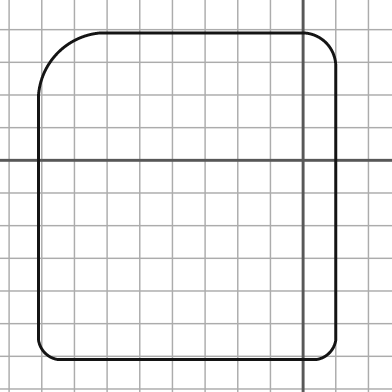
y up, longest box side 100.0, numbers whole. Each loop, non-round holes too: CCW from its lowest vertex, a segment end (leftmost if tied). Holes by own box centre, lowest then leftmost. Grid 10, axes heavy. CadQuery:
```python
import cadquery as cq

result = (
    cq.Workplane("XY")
    .moveTo(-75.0, -61.0)
    .lineTo(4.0, -61.0)
    .threePointArc((8.0, -59.0), (10.0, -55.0))
    .lineTo(10.0, 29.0)
    .threePointArc((7.0, 36.0), (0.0, 39.0))
    .lineTo(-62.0, 39.0)
    .threePointArc((-75.0, 33.0), (-81.0, 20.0))
    .lineTo(-81.0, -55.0)
    .threePointArc((-79.0, -59.0), (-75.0, -61.0))
    .close()
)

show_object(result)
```